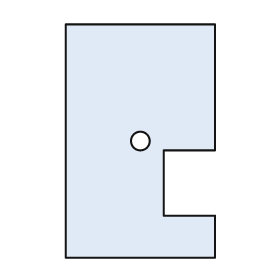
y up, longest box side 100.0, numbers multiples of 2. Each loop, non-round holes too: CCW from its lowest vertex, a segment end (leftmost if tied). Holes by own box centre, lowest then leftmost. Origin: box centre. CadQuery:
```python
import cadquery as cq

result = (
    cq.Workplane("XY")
    .moveTo(-32.0, -50.0)
    .lineTo(32.0, -50.0)
    .lineTo(32.0, -32.0)
    .lineTo(10.0, -32.0)
    .lineTo(10.0, -4.0)
    .lineTo(32.0, -4.0)
    .lineTo(32.0, 50.0)
    .lineTo(-32.0, 50.0)
    .close()
    .moveTo(0.0, 0.0)
    .circle(4.0)
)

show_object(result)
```